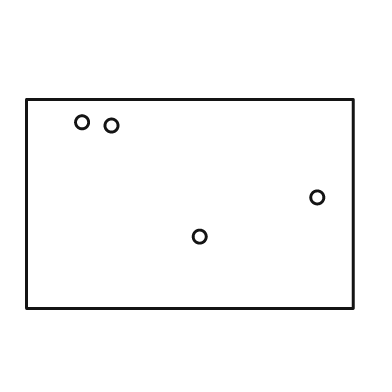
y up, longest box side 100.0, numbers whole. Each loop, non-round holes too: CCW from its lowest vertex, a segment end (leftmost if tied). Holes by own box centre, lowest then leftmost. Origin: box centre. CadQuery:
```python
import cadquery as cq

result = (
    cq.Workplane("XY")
    .moveTo(-50.0, -32.0)
    .lineTo(50.0, -32.0)
    .lineTo(50.0, 32.0)
    .lineTo(-50.0, 32.0)
    .close()
    .moveTo(3.0, -10.0)
    .circle(2.0)
    .moveTo(39.0, 2.0)
    .circle(2.0)
    .moveTo(-24.0, 24.0)
    .circle(2.0)
    .moveTo(-33.0, 25.0)
    .circle(2.0)
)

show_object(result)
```